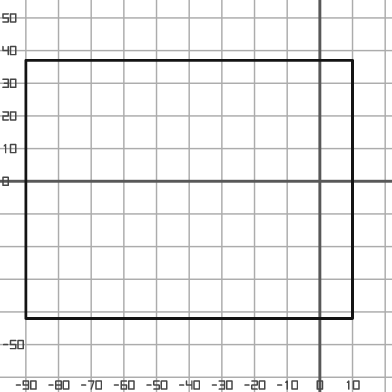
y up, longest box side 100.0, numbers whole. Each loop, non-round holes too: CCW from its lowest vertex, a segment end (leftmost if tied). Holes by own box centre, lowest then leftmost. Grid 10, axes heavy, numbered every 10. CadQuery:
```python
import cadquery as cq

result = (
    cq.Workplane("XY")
    .moveTo(-90.0, -42.0)
    .lineTo(10.0, -42.0)
    .lineTo(10.0, 37.0)
    .lineTo(-90.0, 37.0)
    .close()
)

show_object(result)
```